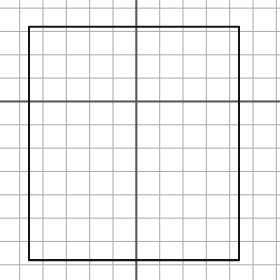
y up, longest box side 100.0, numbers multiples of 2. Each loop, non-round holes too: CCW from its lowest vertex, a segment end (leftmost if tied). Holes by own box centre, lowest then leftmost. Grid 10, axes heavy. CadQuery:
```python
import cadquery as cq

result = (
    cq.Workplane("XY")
    .moveTo(-46.0, -68.0)
    .lineTo(44.0, -68.0)
    .lineTo(44.0, 32.0)
    .lineTo(-46.0, 32.0)
    .close()
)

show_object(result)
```